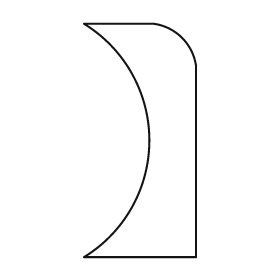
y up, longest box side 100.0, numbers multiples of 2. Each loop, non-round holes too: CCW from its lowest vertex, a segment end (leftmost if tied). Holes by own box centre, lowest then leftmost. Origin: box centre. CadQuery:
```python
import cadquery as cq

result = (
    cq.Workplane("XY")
    .moveTo(-24.0, -50.0)
    .lineTo(24.0, -50.0)
    .lineTo(24.0, 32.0)
    .threePointArc((18.0, 44.0), (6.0, 50.0))
    .lineTo(-24.0, 50.0)
    .threePointArc((4.0, 0.0), (-24.0, -50.0))
    .close()
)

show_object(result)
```